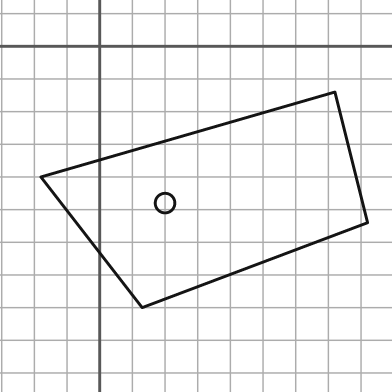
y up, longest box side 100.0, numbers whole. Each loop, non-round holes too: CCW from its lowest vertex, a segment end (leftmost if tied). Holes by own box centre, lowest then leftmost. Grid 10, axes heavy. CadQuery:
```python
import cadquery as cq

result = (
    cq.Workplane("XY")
    .moveTo(13.0, -80.0)
    .lineTo(82.0, -54.0)
    .lineTo(72.0, -14.0)
    .lineTo(-18.0, -40.0)
    .close()
    .moveTo(20.0, -48.0)
    .circle(3.0)
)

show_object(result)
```